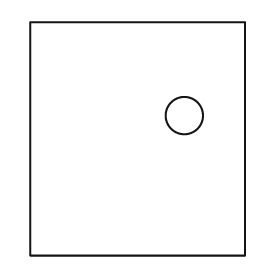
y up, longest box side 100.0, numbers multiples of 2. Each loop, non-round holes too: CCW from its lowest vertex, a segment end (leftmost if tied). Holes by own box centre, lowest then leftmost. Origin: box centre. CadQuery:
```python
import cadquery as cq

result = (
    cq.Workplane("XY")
    .moveTo(-46.0, -50.0)
    .lineTo(46.0, -50.0)
    .lineTo(46.0, 50.0)
    .lineTo(-46.0, 50.0)
    .close()
    .moveTo(20.0, 10.0)
    .circle(8.0)
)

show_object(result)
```